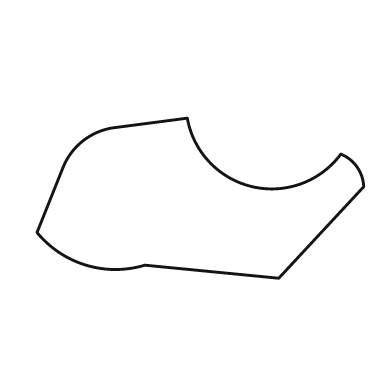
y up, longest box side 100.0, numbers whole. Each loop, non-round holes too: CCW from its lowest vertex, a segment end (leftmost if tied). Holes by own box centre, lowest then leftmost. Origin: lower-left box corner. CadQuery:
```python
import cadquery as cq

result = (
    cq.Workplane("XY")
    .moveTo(74.0, 0.0)
    .lineTo(100.0, 28.0)
    .threePointArc((98.0, 34.0), (93.0, 38.0))
    .threePointArc((66.0, 28.0), (46.0, 49.0))
    .lineTo(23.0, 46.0)
    .threePointArc((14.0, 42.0), (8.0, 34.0))
    .lineTo(0.0, 14.0)
    .threePointArc((15.0, 4.0), (33.0, 4.0))
    .close()
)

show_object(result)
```